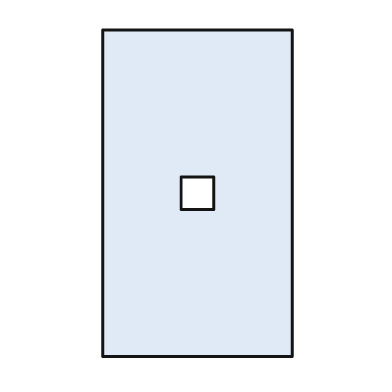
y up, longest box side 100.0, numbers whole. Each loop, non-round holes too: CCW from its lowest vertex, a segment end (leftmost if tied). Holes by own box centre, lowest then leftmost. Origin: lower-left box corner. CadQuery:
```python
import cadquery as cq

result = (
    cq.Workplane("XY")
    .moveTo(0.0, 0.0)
    .lineTo(58.0, 0.0)
    .lineTo(58.0, 100.0)
    .lineTo(0.0, 100.0)
    .close()
    .moveTo(24.0, 45.0)
    .lineTo(34.0, 45.0)
    .lineTo(34.0, 55.0)
    .lineTo(24.0, 55.0)
    .close()
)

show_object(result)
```